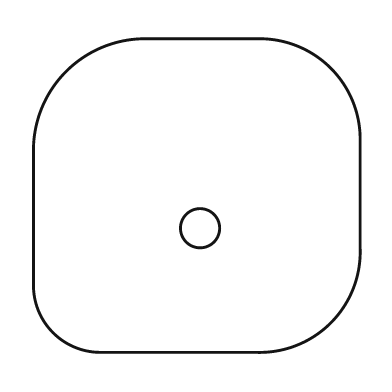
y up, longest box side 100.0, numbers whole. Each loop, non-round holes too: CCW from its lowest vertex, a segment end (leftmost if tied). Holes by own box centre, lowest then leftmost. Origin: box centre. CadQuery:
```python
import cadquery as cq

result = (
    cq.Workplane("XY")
    .moveTo(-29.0, -48.0)
    .lineTo(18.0, -48.0)
    .threePointArc((41.0, -39.0), (50.0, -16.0))
    .lineTo(50.0, 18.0)
    .threePointArc((41.0, 39.0), (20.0, 48.0))
    .lineTo(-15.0, 48.0)
    .threePointArc((-40.0, 38.0), (-50.0, 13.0))
    .lineTo(-50.0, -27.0)
    .threePointArc((-44.0, -42.0), (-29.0, -48.0))
    .close()
    .moveTo(1.0, -10.0)
    .circle(6.0)
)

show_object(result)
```